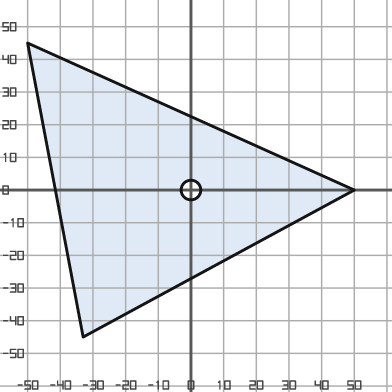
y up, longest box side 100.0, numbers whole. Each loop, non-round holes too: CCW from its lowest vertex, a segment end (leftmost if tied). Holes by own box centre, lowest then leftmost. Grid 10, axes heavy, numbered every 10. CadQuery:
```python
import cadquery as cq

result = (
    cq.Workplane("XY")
    .moveTo(-33.0, -45.0)
    .lineTo(50.0, 0.0)
    .lineTo(-50.0, 45.0)
    .close()
    .moveTo(0.0, 0.0)
    .circle(3.0)
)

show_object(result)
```